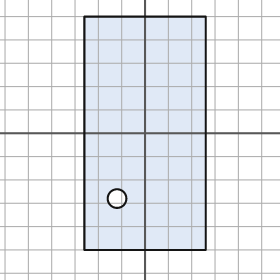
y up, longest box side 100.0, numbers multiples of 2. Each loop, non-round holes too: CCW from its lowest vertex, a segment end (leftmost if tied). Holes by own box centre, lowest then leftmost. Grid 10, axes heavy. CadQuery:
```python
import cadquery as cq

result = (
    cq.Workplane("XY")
    .moveTo(-26.0, -50.0)
    .lineTo(26.0, -50.0)
    .lineTo(26.0, 50.0)
    .lineTo(-26.0, 50.0)
    .close()
    .moveTo(-12.0, -28.0)
    .circle(4.0)
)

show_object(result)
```